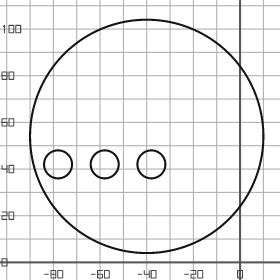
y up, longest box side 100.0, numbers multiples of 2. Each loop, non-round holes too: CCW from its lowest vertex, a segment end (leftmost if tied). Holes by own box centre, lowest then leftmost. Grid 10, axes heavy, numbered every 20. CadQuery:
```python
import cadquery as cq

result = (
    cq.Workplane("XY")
    .moveTo(-40.0, 54.0)
    .circle(50.0)
    .moveTo(-78.0, 42.0)
    .circle(6.0)
    .moveTo(-58.0, 42.0)
    .circle(6.0)
    .moveTo(-38.0, 42.0)
    .circle(6.0)
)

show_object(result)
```